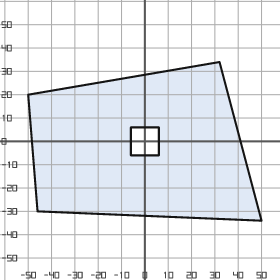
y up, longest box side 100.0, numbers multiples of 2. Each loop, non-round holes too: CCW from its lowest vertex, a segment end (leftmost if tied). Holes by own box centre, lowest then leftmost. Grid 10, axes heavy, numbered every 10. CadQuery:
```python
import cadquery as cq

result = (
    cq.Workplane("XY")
    .moveTo(50.0, -34.0)
    .lineTo(32.0, 34.0)
    .lineTo(-50.0, 20.0)
    .lineTo(-46.0, -30.0)
    .close()
    .moveTo(-6.0, -6.0)
    .lineTo(6.0, -6.0)
    .lineTo(6.0, 6.0)
    .lineTo(-6.0, 6.0)
    .close()
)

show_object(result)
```